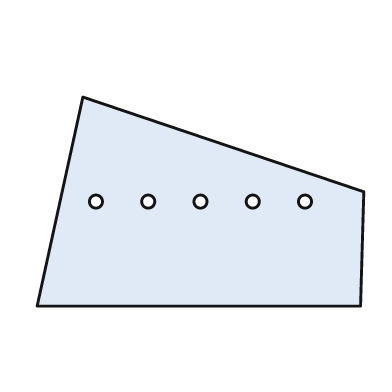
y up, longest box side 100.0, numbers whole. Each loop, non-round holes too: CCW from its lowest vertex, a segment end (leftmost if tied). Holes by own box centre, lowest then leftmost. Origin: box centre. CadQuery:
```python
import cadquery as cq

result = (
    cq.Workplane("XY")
    .moveTo(-50.0, -32.0)
    .lineTo(49.0, -32.0)
    .lineTo(50.0, 3.0)
    .lineTo(-36.0, 32.0)
    .close()
    .moveTo(-32.0, 0.0)
    .circle(2.0)
    .moveTo(-16.0, 0.0)
    .circle(2.0)
    .moveTo(0.0, 0.0)
    .circle(2.0)
    .moveTo(16.0, 0.0)
    .circle(2.0)
    .moveTo(32.0, 0.0)
    .circle(2.0)
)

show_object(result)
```